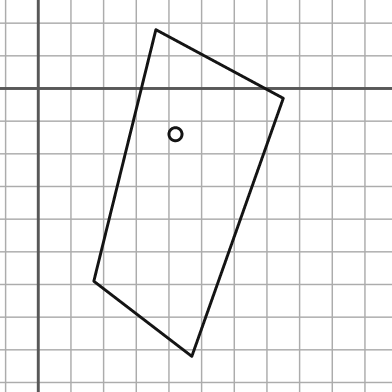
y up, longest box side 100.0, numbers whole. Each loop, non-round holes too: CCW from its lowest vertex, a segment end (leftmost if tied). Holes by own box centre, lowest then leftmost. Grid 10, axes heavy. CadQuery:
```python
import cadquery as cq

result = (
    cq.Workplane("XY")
    .moveTo(47.0, -82.0)
    .lineTo(75.0, -3.0)
    .lineTo(36.0, 18.0)
    .lineTo(17.0, -59.0)
    .close()
    .moveTo(42.0, -14.0)
    .circle(2.0)
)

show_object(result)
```